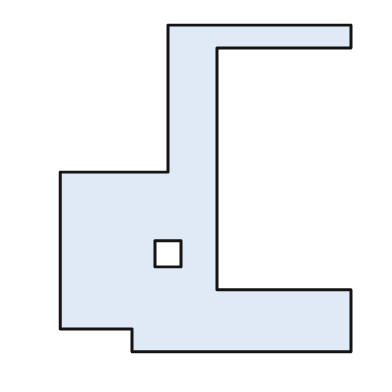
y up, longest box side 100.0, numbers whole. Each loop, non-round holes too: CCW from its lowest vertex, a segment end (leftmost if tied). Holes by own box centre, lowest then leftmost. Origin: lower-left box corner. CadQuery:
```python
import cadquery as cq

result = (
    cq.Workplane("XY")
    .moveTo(22.0, 0.0)
    .lineTo(89.0, 0.0)
    .lineTo(89.0, 19.0)
    .lineTo(48.0, 19.0)
    .lineTo(48.0, 93.0)
    .lineTo(89.0, 93.0)
    .lineTo(89.0, 100.0)
    .lineTo(33.0, 100.0)
    .lineTo(33.0, 55.0)
    .lineTo(0.0, 55.0)
    .lineTo(0.0, 7.0)
    .lineTo(22.0, 7.0)
    .close()
    .moveTo(29.0, 26.0)
    .lineTo(37.0, 26.0)
    .lineTo(37.0, 34.0)
    .lineTo(29.0, 34.0)
    .close()
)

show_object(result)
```